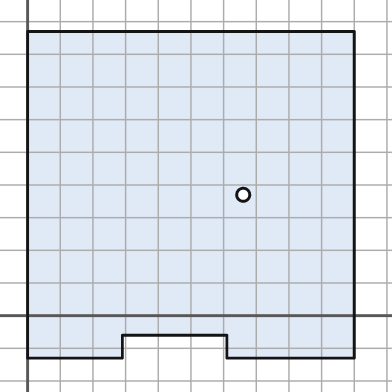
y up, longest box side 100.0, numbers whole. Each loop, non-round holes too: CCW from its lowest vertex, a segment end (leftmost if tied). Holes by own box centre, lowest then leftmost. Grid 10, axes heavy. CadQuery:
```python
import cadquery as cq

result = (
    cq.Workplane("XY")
    .moveTo(0.0, -13.0)
    .lineTo(29.0, -13.0)
    .lineTo(29.0, -6.0)
    .lineTo(61.0, -6.0)
    .lineTo(61.0, -13.0)
    .lineTo(100.0, -13.0)
    .lineTo(100.0, 87.0)
    .lineTo(0.0, 87.0)
    .close()
    .moveTo(66.0, 37.0)
    .circle(2.0)
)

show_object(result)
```